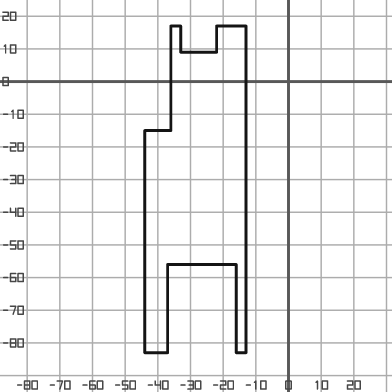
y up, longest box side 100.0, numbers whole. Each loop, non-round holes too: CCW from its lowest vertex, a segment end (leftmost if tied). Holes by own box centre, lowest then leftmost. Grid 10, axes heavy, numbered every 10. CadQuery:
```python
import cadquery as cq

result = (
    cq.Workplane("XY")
    .moveTo(-44.0, -83.0)
    .lineTo(-37.0, -83.0)
    .lineTo(-37.0, -56.0)
    .lineTo(-16.0, -56.0)
    .lineTo(-16.0, -83.0)
    .lineTo(-13.0, -83.0)
    .lineTo(-13.0, 17.0)
    .lineTo(-22.0, 17.0)
    .lineTo(-22.0, 9.0)
    .lineTo(-33.0, 9.0)
    .lineTo(-33.0, 17.0)
    .lineTo(-36.0, 17.0)
    .lineTo(-36.0, -15.0)
    .lineTo(-44.0, -15.0)
    .close()
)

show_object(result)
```